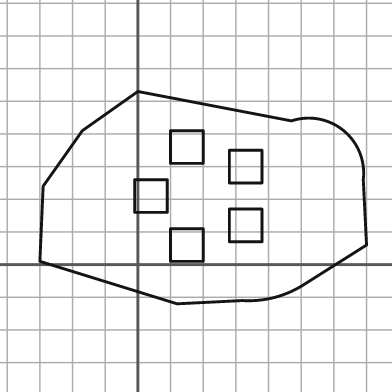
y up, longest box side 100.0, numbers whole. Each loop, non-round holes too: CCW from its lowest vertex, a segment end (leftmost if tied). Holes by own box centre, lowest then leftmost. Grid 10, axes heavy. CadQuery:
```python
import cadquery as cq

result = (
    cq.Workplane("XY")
    .moveTo(12.0, -12.0)
    .lineTo(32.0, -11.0)
    .threePointArc((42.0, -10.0), (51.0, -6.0))
    .lineTo(70.0, 6.0)
    .lineTo(69.0, 26.0)
    .threePointArc((63.0, 41.0), (47.0, 44.0))
    .lineTo(0.0, 53.0)
    .lineTo(-17.0, 41.0)
    .lineTo(-29.0, 24.0)
    .lineTo(-30.0, 1.0)
    .close()
    .moveTo(10.0, 1.0)
    .lineTo(20.0, 1.0)
    .lineTo(20.0, 11.0)
    .lineTo(10.0, 11.0)
    .close()
    .moveTo(28.0, 7.0)
    .lineTo(38.0, 7.0)
    .lineTo(38.0, 17.0)
    .lineTo(28.0, 17.0)
    .close()
    .moveTo(-1.0, 16.0)
    .lineTo(9.0, 16.0)
    .lineTo(9.0, 26.0)
    .lineTo(-1.0, 26.0)
    .close()
    .moveTo(28.0, 25.0)
    .lineTo(38.0, 25.0)
    .lineTo(38.0, 35.0)
    .lineTo(28.0, 35.0)
    .close()
    .moveTo(10.0, 31.0)
    .lineTo(20.0, 31.0)
    .lineTo(20.0, 41.0)
    .lineTo(10.0, 41.0)
    .close()
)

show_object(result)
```